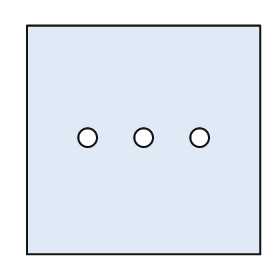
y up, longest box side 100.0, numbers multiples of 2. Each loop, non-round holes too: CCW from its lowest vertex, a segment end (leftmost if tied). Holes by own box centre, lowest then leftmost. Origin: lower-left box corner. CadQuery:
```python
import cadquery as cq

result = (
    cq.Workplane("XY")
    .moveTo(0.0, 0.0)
    .lineTo(100.0, 0.0)
    .lineTo(100.0, 98.0)
    .lineTo(0.0, 98.0)
    .close()
    .moveTo(26.0, 50.0)
    .circle(4.0)
    .moveTo(50.0, 50.0)
    .circle(4.0)
    .moveTo(74.0, 50.0)
    .circle(4.0)
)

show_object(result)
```